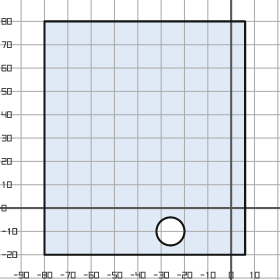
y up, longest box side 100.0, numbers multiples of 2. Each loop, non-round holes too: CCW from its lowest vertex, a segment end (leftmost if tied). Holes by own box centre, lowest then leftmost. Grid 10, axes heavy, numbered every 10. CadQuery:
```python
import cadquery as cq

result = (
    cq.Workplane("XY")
    .moveTo(-80.0, -20.0)
    .lineTo(6.0, -20.0)
    .lineTo(6.0, 80.0)
    .lineTo(-80.0, 80.0)
    .close()
    .moveTo(-26.0, -10.0)
    .circle(6.0)
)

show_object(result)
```